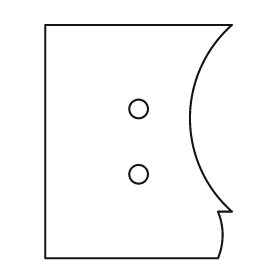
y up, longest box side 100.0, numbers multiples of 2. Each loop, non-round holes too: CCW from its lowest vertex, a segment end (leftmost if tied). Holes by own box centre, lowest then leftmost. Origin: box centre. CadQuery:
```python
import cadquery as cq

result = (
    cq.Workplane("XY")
    .moveTo(-40.0, -50.0)
    .lineTo(34.0, -50.0)
    .threePointArc((36.0, -40.0), (34.0, -30.0))
    .lineTo(40.0, -30.0)
    .threePointArc((22.0, 10.0), (40.0, 50.0))
    .lineTo(-40.0, 50.0)
    .close()
    .moveTo(0.0, -14.0)
    .circle(4.0)
    .moveTo(0.0, 14.0)
    .circle(4.0)
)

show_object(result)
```